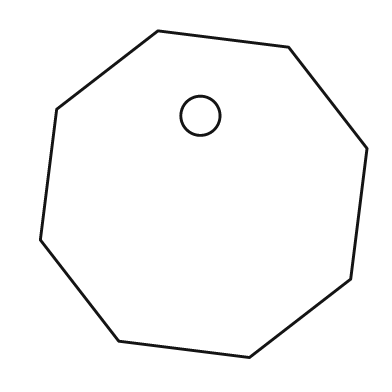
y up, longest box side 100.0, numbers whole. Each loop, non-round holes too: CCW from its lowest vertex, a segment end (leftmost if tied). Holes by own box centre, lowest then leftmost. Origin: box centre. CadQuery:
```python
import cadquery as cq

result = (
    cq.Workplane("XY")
    .moveTo(14.0, -50.0)
    .lineTo(45.0, -26.0)
    .lineTo(50.0, 14.0)
    .lineTo(26.0, 45.0)
    .lineTo(-14.0, 50.0)
    .lineTo(-45.0, 26.0)
    .lineTo(-50.0, -14.0)
    .lineTo(-26.0, -45.0)
    .close()
    .moveTo(-1.0, 24.0)
    .circle(6.0)
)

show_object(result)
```